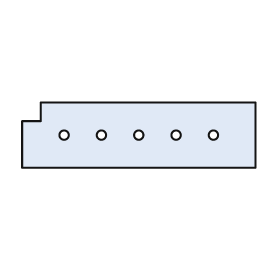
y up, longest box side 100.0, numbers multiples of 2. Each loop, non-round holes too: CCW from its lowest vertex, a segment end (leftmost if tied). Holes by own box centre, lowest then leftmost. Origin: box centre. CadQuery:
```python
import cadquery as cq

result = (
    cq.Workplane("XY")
    .moveTo(-50.0, -14.0)
    .lineTo(50.0, -14.0)
    .lineTo(50.0, 14.0)
    .lineTo(-42.0, 14.0)
    .lineTo(-42.0, 6.0)
    .lineTo(-50.0, 6.0)
    .close()
    .moveTo(-32.0, 0.0)
    .circle(2.0)
    .moveTo(-16.0, 0.0)
    .circle(2.0)
    .moveTo(0.0, 0.0)
    .circle(2.0)
    .moveTo(16.0, 0.0)
    .circle(2.0)
    .moveTo(32.0, 0.0)
    .circle(2.0)
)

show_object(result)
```